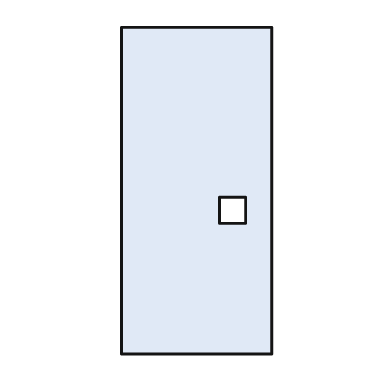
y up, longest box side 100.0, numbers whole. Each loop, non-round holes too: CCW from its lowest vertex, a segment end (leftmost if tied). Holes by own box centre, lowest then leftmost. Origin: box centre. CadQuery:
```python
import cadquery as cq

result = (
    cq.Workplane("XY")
    .moveTo(-23.0, -50.0)
    .lineTo(23.0, -50.0)
    .lineTo(23.0, 50.0)
    .lineTo(-23.0, 50.0)
    .close()
    .moveTo(7.0, -10.0)
    .lineTo(15.0, -10.0)
    .lineTo(15.0, -2.0)
    .lineTo(7.0, -2.0)
    .close()
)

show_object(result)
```